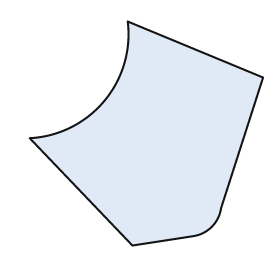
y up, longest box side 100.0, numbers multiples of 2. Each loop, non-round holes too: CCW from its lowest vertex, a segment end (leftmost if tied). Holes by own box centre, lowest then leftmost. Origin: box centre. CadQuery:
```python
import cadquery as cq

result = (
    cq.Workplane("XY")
    .moveTo(-6.0, -48.0)
    .lineTo(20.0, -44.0)
    .threePointArc((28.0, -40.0), (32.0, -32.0))
    .lineTo(50.0, 24.0)
    .lineTo(-8.0, 48.0)
    .threePointArc((-18.0, 14.0), (-50.0, -2.0))
    .close()
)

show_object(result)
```